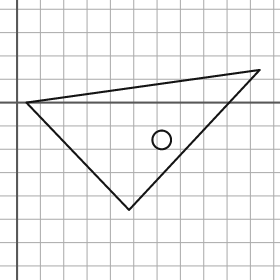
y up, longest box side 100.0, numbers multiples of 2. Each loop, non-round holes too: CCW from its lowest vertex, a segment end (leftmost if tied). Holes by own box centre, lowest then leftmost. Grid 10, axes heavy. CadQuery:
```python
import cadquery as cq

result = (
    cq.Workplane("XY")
    .moveTo(48.0, -46.0)
    .lineTo(104.0, 14.0)
    .lineTo(4.0, 0.0)
    .close()
    .moveTo(62.0, -16.0)
    .circle(4.0)
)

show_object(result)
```